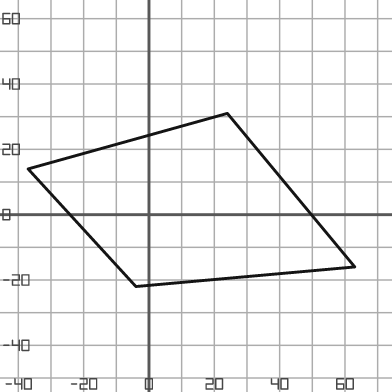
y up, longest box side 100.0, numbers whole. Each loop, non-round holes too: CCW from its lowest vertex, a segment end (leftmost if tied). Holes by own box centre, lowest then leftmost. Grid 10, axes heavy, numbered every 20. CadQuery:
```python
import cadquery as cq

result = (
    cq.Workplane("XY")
    .moveTo(-4.0, -22.0)
    .lineTo(63.0, -16.0)
    .lineTo(24.0, 31.0)
    .lineTo(-37.0, 14.0)
    .close()
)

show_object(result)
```